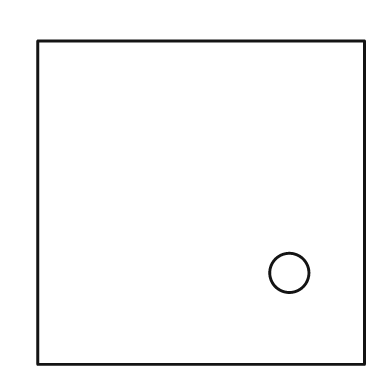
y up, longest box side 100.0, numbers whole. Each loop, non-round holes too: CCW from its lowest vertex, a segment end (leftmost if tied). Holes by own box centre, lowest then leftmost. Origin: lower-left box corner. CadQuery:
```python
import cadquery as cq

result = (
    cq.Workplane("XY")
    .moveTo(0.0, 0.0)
    .lineTo(100.0, 0.0)
    .lineTo(100.0, 99.0)
    .lineTo(0.0, 99.0)
    .close()
    .moveTo(77.0, 28.0)
    .circle(6.0)
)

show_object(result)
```